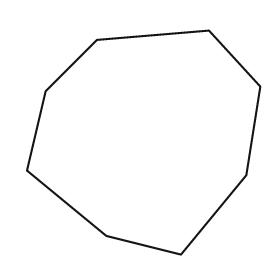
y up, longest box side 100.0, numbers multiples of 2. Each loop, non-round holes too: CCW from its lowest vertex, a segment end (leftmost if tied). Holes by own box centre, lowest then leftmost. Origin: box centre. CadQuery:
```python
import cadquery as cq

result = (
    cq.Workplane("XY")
    .moveTo(16.0, -48.0)
    .lineTo(44.0, -14.0)
    .lineTo(50.0, 24.0)
    .lineTo(28.0, 48.0)
    .lineTo(-20.0, 44.0)
    .lineTo(-42.0, 22.0)
    .lineTo(-50.0, -12.0)
    .lineTo(-16.0, -40.0)
    .close()
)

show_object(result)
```